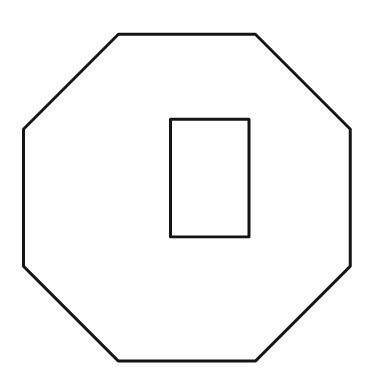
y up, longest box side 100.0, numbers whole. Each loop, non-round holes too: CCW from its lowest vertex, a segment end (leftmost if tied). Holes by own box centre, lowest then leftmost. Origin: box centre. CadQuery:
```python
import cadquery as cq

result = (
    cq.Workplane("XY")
    .moveTo(-21.0, -50.0)
    .lineTo(21.0, -50.0)
    .lineTo(50.0, -21.0)
    .lineTo(50.0, 21.0)
    .lineTo(21.0, 50.0)
    .lineTo(-21.0, 50.0)
    .lineTo(-50.0, 21.0)
    .lineTo(-50.0, -21.0)
    .close()
    .moveTo(-5.0, -12.0)
    .lineTo(19.0, -12.0)
    .lineTo(19.0, 24.0)
    .lineTo(-5.0, 24.0)
    .close()
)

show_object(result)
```